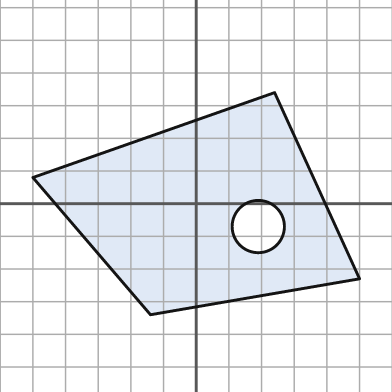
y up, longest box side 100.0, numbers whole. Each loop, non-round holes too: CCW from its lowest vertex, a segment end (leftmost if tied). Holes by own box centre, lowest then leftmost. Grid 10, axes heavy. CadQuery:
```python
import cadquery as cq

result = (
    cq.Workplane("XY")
    .moveTo(-14.0, -34.0)
    .lineTo(50.0, -23.0)
    .lineTo(24.0, 34.0)
    .lineTo(-50.0, 8.0)
    .close()
    .moveTo(19.0, -7.0)
    .circle(8.0)
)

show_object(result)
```